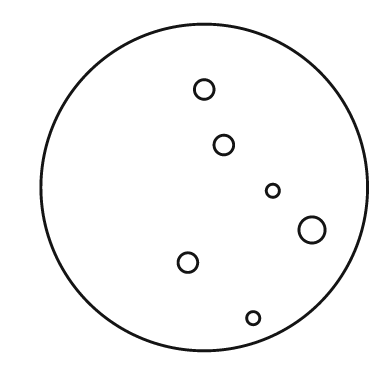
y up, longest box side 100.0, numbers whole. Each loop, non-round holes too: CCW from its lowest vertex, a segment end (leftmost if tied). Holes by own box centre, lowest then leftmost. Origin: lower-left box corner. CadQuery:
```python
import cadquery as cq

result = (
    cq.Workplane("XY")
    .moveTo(50.0, 50.0)
    .circle(50.0)
    .moveTo(65.0, 10.0)
    .circle(2.0)
    .moveTo(45.0, 27.0)
    .circle(3.0)
    .moveTo(83.0, 37.0)
    .circle(4.0)
    .moveTo(71.0, 49.0)
    .circle(2.0)
    .moveTo(56.0, 63.0)
    .circle(3.0)
    .moveTo(50.0, 80.0)
    .circle(3.0)
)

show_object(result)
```